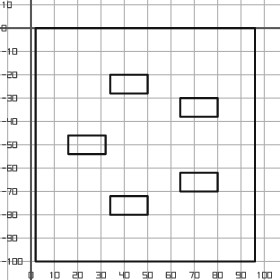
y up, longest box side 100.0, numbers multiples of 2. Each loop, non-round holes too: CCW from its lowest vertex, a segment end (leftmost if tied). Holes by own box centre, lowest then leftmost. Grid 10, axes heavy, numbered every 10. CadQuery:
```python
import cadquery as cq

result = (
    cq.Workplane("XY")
    .moveTo(2.0, -100.0)
    .lineTo(96.0, -100.0)
    .lineTo(96.0, 0.0)
    .lineTo(2.0, 0.0)
    .close()
    .moveTo(34.0, -80.0)
    .lineTo(50.0, -80.0)
    .lineTo(50.0, -72.0)
    .lineTo(34.0, -72.0)
    .close()
    .moveTo(64.0, -70.0)
    .lineTo(80.0, -70.0)
    .lineTo(80.0, -62.0)
    .lineTo(64.0, -62.0)
    .close()
    .moveTo(16.0, -54.0)
    .lineTo(32.0, -54.0)
    .lineTo(32.0, -46.0)
    .lineTo(16.0, -46.0)
    .close()
    .moveTo(64.0, -38.0)
    .lineTo(80.0, -38.0)
    .lineTo(80.0, -30.0)
    .lineTo(64.0, -30.0)
    .close()
    .moveTo(34.0, -28.0)
    .lineTo(50.0, -28.0)
    .lineTo(50.0, -20.0)
    .lineTo(34.0, -20.0)
    .close()
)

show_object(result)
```